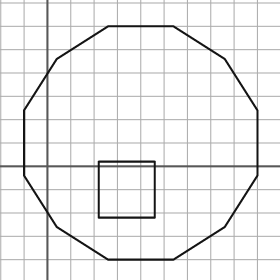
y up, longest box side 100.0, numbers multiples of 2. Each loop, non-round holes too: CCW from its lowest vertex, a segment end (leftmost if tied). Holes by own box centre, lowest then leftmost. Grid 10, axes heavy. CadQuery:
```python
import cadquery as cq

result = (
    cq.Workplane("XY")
    .moveTo(26.0, -40.0)
    .lineTo(54.0, -40.0)
    .lineTo(76.0, -26.0)
    .lineTo(90.0, -4.0)
    .lineTo(90.0, 24.0)
    .lineTo(76.0, 46.0)
    .lineTo(54.0, 60.0)
    .lineTo(26.0, 60.0)
    .lineTo(4.0, 46.0)
    .lineTo(-10.0, 24.0)
    .lineTo(-10.0, -4.0)
    .lineTo(4.0, -26.0)
    .close()
    .moveTo(22.0, -22.0)
    .lineTo(46.0, -22.0)
    .lineTo(46.0, 2.0)
    .lineTo(22.0, 2.0)
    .close()
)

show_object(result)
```